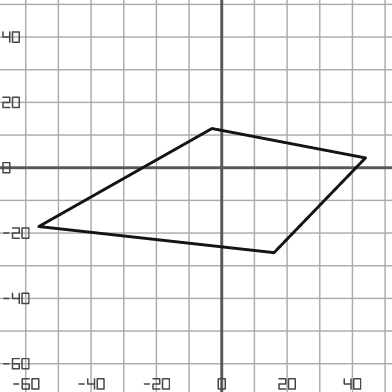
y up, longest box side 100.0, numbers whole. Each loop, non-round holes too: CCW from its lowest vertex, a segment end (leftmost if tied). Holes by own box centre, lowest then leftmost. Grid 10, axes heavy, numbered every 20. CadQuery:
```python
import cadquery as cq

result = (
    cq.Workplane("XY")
    .moveTo(16.0, -26.0)
    .lineTo(44.0, 3.0)
    .lineTo(-3.0, 12.0)
    .lineTo(-56.0, -18.0)
    .close()
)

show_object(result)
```